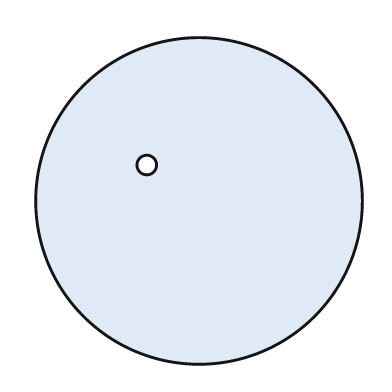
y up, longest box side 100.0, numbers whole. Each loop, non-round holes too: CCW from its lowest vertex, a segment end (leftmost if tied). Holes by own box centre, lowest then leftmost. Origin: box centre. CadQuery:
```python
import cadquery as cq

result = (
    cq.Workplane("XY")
    .moveTo(0.0, 0.0)
    .circle(50.0)
    .moveTo(-16.0, 11.0)
    .circle(3.0)
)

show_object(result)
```